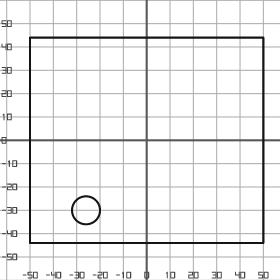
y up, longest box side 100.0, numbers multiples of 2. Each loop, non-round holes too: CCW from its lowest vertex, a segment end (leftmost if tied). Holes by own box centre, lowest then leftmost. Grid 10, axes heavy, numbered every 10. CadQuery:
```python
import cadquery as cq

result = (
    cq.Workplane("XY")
    .moveTo(-50.0, -44.0)
    .lineTo(50.0, -44.0)
    .lineTo(50.0, 44.0)
    .lineTo(-50.0, 44.0)
    .close()
    .moveTo(-26.0, -30.0)
    .circle(6.0)
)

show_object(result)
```